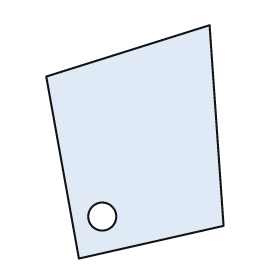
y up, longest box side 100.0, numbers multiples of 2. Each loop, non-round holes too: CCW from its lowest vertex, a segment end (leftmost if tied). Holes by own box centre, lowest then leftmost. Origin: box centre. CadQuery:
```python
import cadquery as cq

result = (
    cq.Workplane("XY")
    .moveTo(-24.0, -50.0)
    .lineTo(38.0, -36.0)
    .lineTo(32.0, 50.0)
    .lineTo(-38.0, 28.0)
    .close()
    .moveTo(-14.0, -32.0)
    .circle(6.0)
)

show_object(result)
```